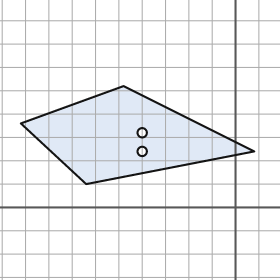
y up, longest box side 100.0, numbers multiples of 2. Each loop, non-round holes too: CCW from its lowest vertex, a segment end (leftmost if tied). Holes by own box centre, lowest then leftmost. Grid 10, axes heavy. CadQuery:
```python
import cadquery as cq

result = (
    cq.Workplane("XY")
    .moveTo(-64.0, 10.0)
    .lineTo(8.0, 24.0)
    .lineTo(-48.0, 52.0)
    .lineTo(-92.0, 36.0)
    .close()
    .moveTo(-40.0, 24.0)
    .circle(2.0)
    .moveTo(-40.0, 32.0)
    .circle(2.0)
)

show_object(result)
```